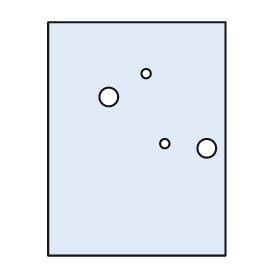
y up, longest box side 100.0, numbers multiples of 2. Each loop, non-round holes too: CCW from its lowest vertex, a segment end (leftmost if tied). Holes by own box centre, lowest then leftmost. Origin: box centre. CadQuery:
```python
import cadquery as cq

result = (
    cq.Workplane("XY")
    .moveTo(-38.0, -50.0)
    .lineTo(38.0, -50.0)
    .lineTo(38.0, 50.0)
    .lineTo(-38.0, 50.0)
    .close()
    .moveTo(30.0, -4.0)
    .circle(4.0)
    .moveTo(12.0, -2.0)
    .circle(2.0)
    .moveTo(-12.0, 18.0)
    .circle(4.0)
    .moveTo(4.0, 28.0)
    .circle(2.0)
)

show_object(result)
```